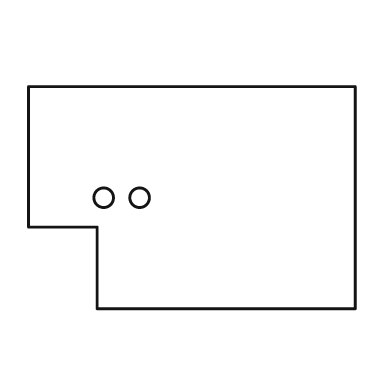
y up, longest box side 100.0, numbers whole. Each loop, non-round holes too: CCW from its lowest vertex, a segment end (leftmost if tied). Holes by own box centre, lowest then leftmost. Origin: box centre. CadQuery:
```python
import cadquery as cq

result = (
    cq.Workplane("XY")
    .moveTo(-29.0, -34.0)
    .lineTo(50.0, -34.0)
    .lineTo(50.0, 34.0)
    .lineTo(-50.0, 34.0)
    .lineTo(-50.0, -9.0)
    .lineTo(-29.0, -9.0)
    .close()
    .moveTo(-27.0, 0.0)
    .circle(3.0)
    .moveTo(-16.0, 0.0)
    .circle(3.0)
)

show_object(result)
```